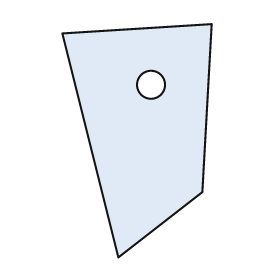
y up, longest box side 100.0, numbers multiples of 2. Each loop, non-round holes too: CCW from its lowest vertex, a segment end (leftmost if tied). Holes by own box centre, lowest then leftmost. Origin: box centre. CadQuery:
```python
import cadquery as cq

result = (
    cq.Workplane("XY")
    .moveTo(-8.0, -50.0)
    .lineTo(28.0, -22.0)
    .lineTo(32.0, 50.0)
    .lineTo(-32.0, 46.0)
    .close()
    .moveTo(6.0, 24.0)
    .circle(6.0)
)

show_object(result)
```